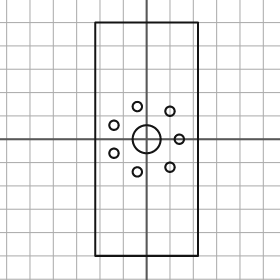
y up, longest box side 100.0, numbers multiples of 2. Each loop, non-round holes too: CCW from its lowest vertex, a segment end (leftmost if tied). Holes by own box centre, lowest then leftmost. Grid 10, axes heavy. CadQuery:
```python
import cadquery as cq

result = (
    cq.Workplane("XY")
    .moveTo(-22.0, -50.0)
    .lineTo(22.0, -50.0)
    .lineTo(22.0, 50.0)
    .lineTo(-22.0, 50.0)
    .close()
    .moveTo(-4.0, -14.0)
    .circle(2.0)
    .moveTo(10.0, -12.0)
    .circle(2.0)
    .moveTo(-14.0, -6.0)
    .circle(2.0)
    .moveTo(0.0, 0.0)
    .circle(6.0)
    .moveTo(14.0, 0.0)
    .circle(2.0)
    .moveTo(-14.0, 6.0)
    .circle(2.0)
    .moveTo(10.0, 12.0)
    .circle(2.0)
    .moveTo(-4.0, 14.0)
    .circle(2.0)
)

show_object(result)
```